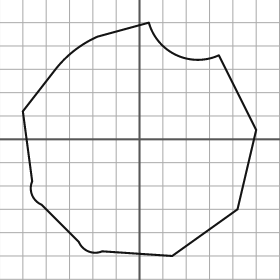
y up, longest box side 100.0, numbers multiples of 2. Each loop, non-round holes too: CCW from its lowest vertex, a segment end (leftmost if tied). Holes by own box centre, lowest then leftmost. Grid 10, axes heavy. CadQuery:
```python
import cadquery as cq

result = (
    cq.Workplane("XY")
    .moveTo(14.0, -50.0)
    .lineTo(42.0, -30.0)
    .lineTo(50.0, 4.0)
    .lineTo(34.0, 36.0)
    .threePointArc((16.0, 36.0), (4.0, 50.0))
    .lineTo(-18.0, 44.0)
    .threePointArc((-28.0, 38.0), (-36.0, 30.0))
    .lineTo(-50.0, 12.0)
    .lineTo(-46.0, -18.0)
    .threePointArc((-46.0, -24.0), (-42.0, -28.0))
    .lineTo(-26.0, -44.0)
    .threePointArc((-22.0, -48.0), (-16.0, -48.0))
    .close()
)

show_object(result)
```